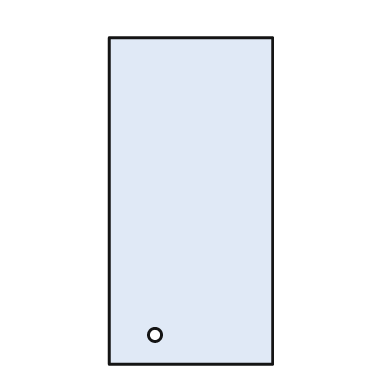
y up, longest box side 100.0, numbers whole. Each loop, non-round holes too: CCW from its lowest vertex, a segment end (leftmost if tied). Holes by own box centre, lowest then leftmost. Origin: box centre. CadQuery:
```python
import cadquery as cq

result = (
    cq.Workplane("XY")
    .moveTo(-25.0, -50.0)
    .lineTo(25.0, -50.0)
    .lineTo(25.0, 50.0)
    .lineTo(-25.0, 50.0)
    .close()
    .moveTo(-11.0, -41.0)
    .circle(2.0)
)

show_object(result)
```